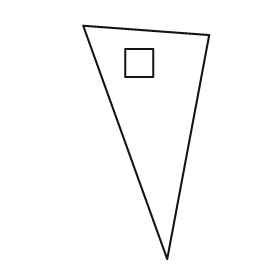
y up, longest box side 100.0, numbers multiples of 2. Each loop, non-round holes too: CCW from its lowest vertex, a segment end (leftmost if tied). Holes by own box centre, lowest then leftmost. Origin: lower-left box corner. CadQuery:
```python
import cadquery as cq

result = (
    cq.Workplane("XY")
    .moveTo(36.0, 0.0)
    .lineTo(54.0, 96.0)
    .lineTo(0.0, 100.0)
    .close()
    .moveTo(18.0, 78.0)
    .lineTo(30.0, 78.0)
    .lineTo(30.0, 90.0)
    .lineTo(18.0, 90.0)
    .close()
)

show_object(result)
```